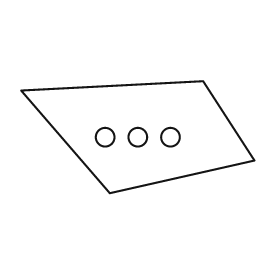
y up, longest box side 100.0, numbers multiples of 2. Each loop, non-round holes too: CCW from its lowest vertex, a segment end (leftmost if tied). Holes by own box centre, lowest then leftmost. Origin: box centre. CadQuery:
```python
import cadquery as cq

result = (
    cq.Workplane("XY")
    .moveTo(-12.0, -24.0)
    .lineTo(50.0, -10.0)
    .lineTo(28.0, 24.0)
    .lineTo(-50.0, 20.0)
    .close()
    .moveTo(-14.0, 0.0)
    .circle(4.0)
    .moveTo(0.0, 0.0)
    .circle(4.0)
    .moveTo(14.0, 0.0)
    .circle(4.0)
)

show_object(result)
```